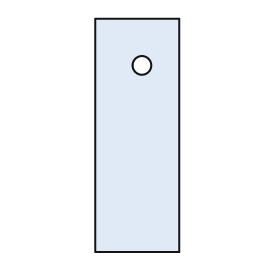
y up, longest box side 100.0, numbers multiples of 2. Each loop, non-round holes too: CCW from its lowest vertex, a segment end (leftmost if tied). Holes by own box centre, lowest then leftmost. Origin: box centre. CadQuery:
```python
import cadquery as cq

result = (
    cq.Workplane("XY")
    .moveTo(-18.0, -50.0)
    .lineTo(18.0, -50.0)
    .lineTo(18.0, 50.0)
    .lineTo(-18.0, 50.0)
    .close()
    .moveTo(2.0, 30.0)
    .circle(4.0)
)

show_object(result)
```